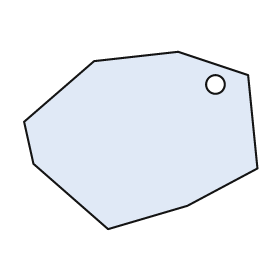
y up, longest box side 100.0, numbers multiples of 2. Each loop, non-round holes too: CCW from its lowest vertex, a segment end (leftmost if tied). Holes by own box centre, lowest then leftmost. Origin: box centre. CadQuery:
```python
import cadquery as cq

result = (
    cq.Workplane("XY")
    .moveTo(-14.0, -38.0)
    .lineTo(20.0, -28.0)
    .lineTo(50.0, -12.0)
    .lineTo(46.0, 28.0)
    .lineTo(16.0, 38.0)
    .lineTo(-20.0, 34.0)
    .lineTo(-50.0, 8.0)
    .lineTo(-46.0, -10.0)
    .close()
    .moveTo(32.0, 24.0)
    .circle(4.0)
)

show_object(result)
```